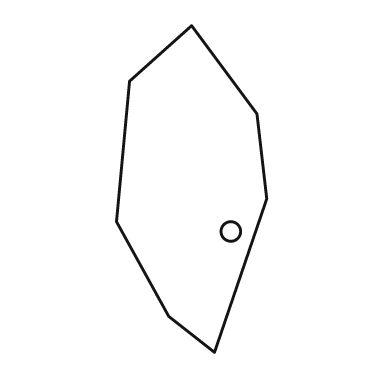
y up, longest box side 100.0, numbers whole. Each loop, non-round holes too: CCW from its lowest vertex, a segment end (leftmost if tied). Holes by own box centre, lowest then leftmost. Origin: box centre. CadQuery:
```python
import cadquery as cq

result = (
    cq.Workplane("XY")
    .moveTo(7.0, -50.0)
    .lineTo(23.0, -3.0)
    .lineTo(20.0, 23.0)
    .lineTo(0.0, 50.0)
    .lineTo(-19.0, 33.0)
    .lineTo(-23.0, -10.0)
    .lineTo(-7.0, -39.0)
    .close()
    .moveTo(12.0, -13.0)
    .circle(3.0)
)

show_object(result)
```